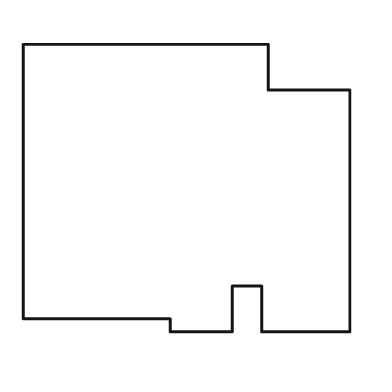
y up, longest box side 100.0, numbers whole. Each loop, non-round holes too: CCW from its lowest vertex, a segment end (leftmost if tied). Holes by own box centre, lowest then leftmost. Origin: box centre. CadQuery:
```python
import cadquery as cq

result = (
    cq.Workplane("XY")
    .moveTo(-5.0, -44.0)
    .lineTo(14.0, -44.0)
    .lineTo(14.0, -30.0)
    .lineTo(23.0, -30.0)
    .lineTo(23.0, -44.0)
    .lineTo(50.0, -44.0)
    .lineTo(50.0, 30.0)
    .lineTo(25.0, 30.0)
    .lineTo(25.0, 44.0)
    .lineTo(-50.0, 44.0)
    .lineTo(-50.0, -40.0)
    .lineTo(-5.0, -40.0)
    .close()
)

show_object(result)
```